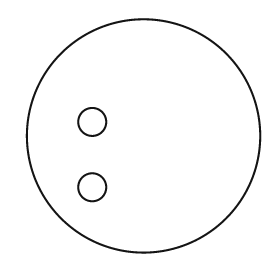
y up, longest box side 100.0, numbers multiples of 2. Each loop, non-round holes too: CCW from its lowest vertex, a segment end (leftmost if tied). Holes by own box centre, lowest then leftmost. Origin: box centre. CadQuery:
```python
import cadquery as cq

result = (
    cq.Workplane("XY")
    .moveTo(0.0, 0.0)
    .circle(50.0)
    .moveTo(-22.0, -22.0)
    .circle(6.0)
    .moveTo(-22.0, 6.0)
    .circle(6.0)
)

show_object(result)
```